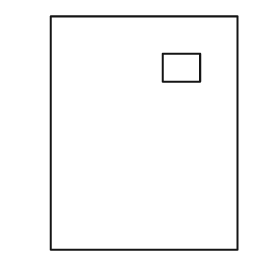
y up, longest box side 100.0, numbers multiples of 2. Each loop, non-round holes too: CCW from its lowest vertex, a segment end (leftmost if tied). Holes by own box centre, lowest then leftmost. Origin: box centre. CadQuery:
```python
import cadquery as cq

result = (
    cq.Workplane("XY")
    .moveTo(-40.0, -50.0)
    .lineTo(40.0, -50.0)
    .lineTo(40.0, 50.0)
    .lineTo(-40.0, 50.0)
    .close()
    .moveTo(8.0, 22.0)
    .lineTo(24.0, 22.0)
    .lineTo(24.0, 34.0)
    .lineTo(8.0, 34.0)
    .close()
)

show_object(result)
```